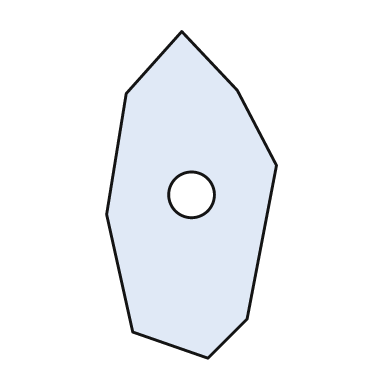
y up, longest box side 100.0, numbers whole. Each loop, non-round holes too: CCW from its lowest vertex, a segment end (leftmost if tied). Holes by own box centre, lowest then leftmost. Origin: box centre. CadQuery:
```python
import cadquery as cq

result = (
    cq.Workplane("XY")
    .moveTo(5.0, -50.0)
    .lineTo(17.0, -38.0)
    .lineTo(26.0, 9.0)
    .lineTo(14.0, 32.0)
    .lineTo(-3.0, 50.0)
    .lineTo(-20.0, 31.0)
    .lineTo(-26.0, -6.0)
    .lineTo(-18.0, -42.0)
    .close()
    .moveTo(0.0, 0.0)
    .circle(7.0)
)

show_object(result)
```